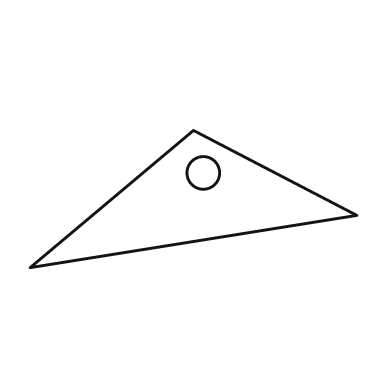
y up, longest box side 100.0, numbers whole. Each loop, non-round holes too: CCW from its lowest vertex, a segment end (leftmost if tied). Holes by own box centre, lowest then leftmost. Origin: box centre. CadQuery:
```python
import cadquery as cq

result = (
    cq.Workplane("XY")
    .moveTo(-50.0, -21.0)
    .lineTo(50.0, -5.0)
    .lineTo(0.0, 21.0)
    .close()
    .moveTo(3.0, 8.0)
    .circle(5.0)
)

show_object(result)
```